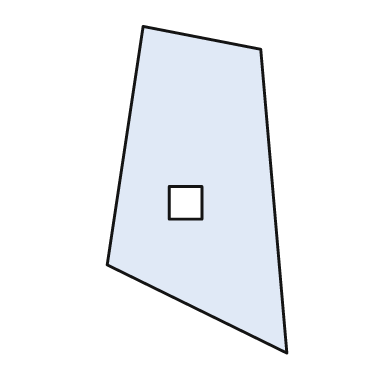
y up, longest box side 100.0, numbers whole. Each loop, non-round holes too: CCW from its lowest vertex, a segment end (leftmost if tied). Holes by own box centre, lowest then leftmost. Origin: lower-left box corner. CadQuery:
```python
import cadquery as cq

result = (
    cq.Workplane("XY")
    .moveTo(55.0, 0.0)
    .lineTo(47.0, 93.0)
    .lineTo(11.0, 100.0)
    .lineTo(0.0, 27.0)
    .close()
    .moveTo(19.0, 41.0)
    .lineTo(29.0, 41.0)
    .lineTo(29.0, 51.0)
    .lineTo(19.0, 51.0)
    .close()
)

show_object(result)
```